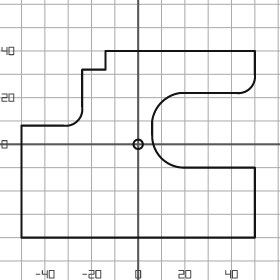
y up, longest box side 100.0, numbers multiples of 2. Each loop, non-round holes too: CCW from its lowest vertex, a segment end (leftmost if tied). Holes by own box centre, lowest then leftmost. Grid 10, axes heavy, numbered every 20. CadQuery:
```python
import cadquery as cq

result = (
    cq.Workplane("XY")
    .moveTo(-50.0, -40.0)
    .lineTo(50.0, -40.0)
    .lineTo(50.0, -10.0)
    .lineTo(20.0, -10.0)
    .threePointArc((10.0, -6.0), (6.0, 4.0))
    .lineTo(6.0, 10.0)
    .threePointArc((10.0, 18.0), (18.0, 22.0))
    .lineTo(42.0, 22.0)
    .threePointArc((48.0, 24.0), (50.0, 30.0))
    .lineTo(50.0, 40.0)
    .lineTo(-14.0, 40.0)
    .lineTo(-14.0, 32.0)
    .lineTo(-24.0, 32.0)
    .lineTo(-24.0, 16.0)
    .threePointArc((-26.0, 10.0), (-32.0, 8.0))
    .lineTo(-50.0, 8.0)
    .close()
    .moveTo(0.0, 0.0)
    .circle(2.0)
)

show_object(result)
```